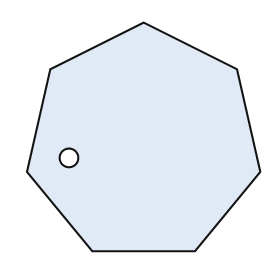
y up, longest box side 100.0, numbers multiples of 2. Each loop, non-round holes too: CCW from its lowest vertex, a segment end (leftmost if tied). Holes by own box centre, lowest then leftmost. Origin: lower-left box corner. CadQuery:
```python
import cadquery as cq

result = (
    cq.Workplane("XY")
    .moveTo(28.0, 0.0)
    .lineTo(72.0, 0.0)
    .lineTo(100.0, 34.0)
    .lineTo(90.0, 78.0)
    .lineTo(50.0, 98.0)
    .lineTo(10.0, 78.0)
    .lineTo(0.0, 34.0)
    .close()
    .moveTo(18.0, 40.0)
    .circle(4.0)
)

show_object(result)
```